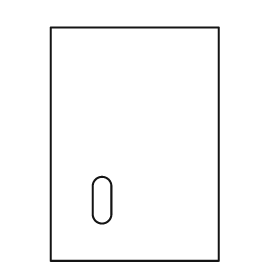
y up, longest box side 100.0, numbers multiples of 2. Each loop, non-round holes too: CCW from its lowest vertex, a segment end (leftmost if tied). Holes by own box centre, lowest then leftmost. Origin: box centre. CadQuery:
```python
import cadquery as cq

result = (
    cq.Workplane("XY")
    .moveTo(-36.0, -50.0)
    .lineTo(36.0, -50.0)
    .lineTo(36.0, 50.0)
    .lineTo(-36.0, 50.0)
    .close()
    .moveTo(-18.0, -30.0)
    .threePointArc((-14.0, -34.0), (-10.0, -30.0))
    .lineTo(-10.0, -18.0)
    .threePointArc((-14.0, -14.0), (-18.0, -18.0))
    .close()
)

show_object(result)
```